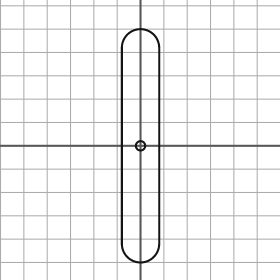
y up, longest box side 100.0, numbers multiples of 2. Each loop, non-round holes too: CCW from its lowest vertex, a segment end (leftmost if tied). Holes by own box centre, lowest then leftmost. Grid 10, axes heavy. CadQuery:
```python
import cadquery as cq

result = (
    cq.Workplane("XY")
    .moveTo(-8.0, -42.0)
    .threePointArc((0.0, -50.0), (8.0, -42.0))
    .lineTo(8.0, 42.0)
    .threePointArc((0.0, 50.0), (-8.0, 42.0))
    .close()
    .moveTo(0.0, 0.0)
    .circle(2.0)
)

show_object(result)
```